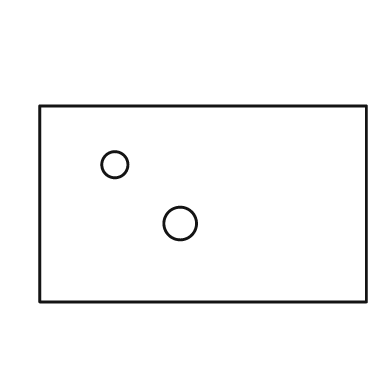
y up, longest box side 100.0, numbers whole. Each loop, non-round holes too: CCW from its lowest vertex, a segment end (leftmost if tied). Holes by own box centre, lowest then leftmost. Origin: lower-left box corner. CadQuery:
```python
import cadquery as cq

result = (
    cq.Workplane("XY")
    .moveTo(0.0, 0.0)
    .lineTo(100.0, 0.0)
    .lineTo(100.0, 60.0)
    .lineTo(0.0, 60.0)
    .close()
    .moveTo(43.0, 24.0)
    .circle(5.0)
    .moveTo(23.0, 42.0)
    .circle(4.0)
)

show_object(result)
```